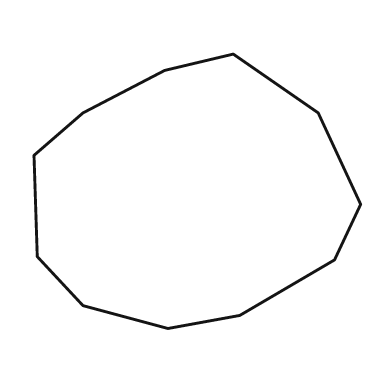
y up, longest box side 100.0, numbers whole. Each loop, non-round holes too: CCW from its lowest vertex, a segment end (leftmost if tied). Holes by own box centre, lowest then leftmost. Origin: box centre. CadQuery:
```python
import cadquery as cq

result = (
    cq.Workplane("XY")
    .moveTo(-9.0, -42.0)
    .lineTo(13.0, -38.0)
    .lineTo(42.0, -21.0)
    .lineTo(50.0, -4.0)
    .lineTo(37.0, 24.0)
    .lineTo(11.0, 42.0)
    .lineTo(-10.0, 37.0)
    .lineTo(-35.0, 24.0)
    .lineTo(-50.0, 11.0)
    .lineTo(-49.0, -20.0)
    .lineTo(-35.0, -35.0)
    .close()
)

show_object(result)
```